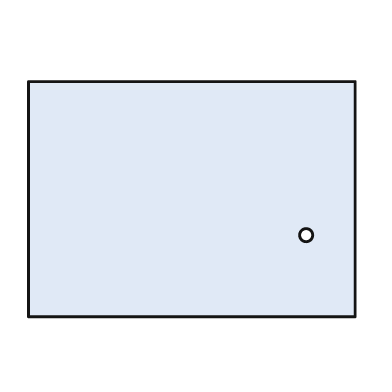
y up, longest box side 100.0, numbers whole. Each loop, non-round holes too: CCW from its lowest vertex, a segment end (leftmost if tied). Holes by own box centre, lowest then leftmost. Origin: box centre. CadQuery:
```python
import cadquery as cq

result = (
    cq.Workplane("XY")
    .moveTo(-50.0, -36.0)
    .lineTo(50.0, -36.0)
    .lineTo(50.0, 36.0)
    .lineTo(-50.0, 36.0)
    .close()
    .moveTo(35.0, -11.0)
    .circle(2.0)
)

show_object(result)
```